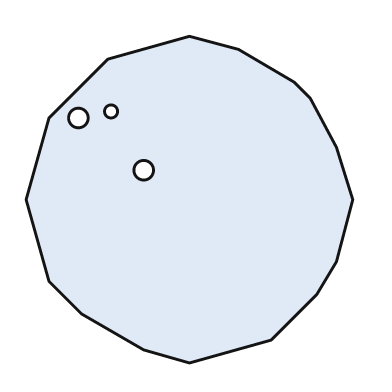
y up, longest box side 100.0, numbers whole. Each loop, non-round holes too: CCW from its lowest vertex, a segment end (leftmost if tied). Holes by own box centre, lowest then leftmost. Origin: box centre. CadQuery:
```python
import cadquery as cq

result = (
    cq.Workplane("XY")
    .moveTo(0.0, -50.0)
    .lineTo(25.0, -43.0)
    .lineTo(39.0, -29.0)
    .lineTo(45.0, -19.0)
    .lineTo(50.0, 0.0)
    .lineTo(45.0, 16.0)
    .lineTo(37.0, 31.0)
    .lineTo(32.0, 36.0)
    .lineTo(15.0, 46.0)
    .lineTo(0.0, 50.0)
    .lineTo(-25.0, 43.0)
    .lineTo(-43.0, 25.0)
    .lineTo(-50.0, 0.0)
    .lineTo(-43.0, -25.0)
    .lineTo(-33.0, -35.0)
    .lineTo(-14.0, -46.0)
    .close()
    .moveTo(-14.0, 9.0)
    .circle(3.0)
    .moveTo(-34.0, 25.0)
    .circle(3.0)
    .moveTo(-24.0, 27.0)
    .circle(2.0)
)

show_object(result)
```